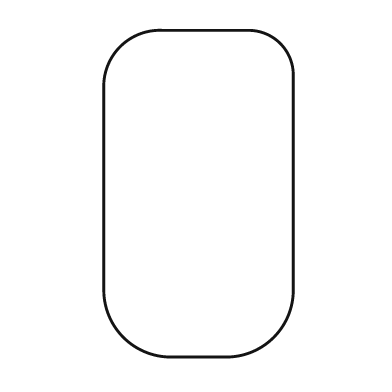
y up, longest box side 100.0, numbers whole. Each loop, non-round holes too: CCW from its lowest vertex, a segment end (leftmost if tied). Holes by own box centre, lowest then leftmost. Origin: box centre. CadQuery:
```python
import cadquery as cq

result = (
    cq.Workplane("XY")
    .moveTo(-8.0, -50.0)
    .lineTo(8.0, -50.0)
    .threePointArc((23.0, -44.0), (29.0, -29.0))
    .lineTo(29.0, 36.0)
    .threePointArc((25.0, 46.0), (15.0, 50.0))
    .lineTo(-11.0, 50.0)
    .threePointArc((-24.0, 45.0), (-29.0, 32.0))
    .lineTo(-29.0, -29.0)
    .threePointArc((-23.0, -44.0), (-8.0, -50.0))
    .close()
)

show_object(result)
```